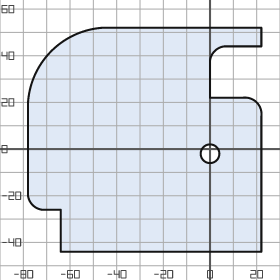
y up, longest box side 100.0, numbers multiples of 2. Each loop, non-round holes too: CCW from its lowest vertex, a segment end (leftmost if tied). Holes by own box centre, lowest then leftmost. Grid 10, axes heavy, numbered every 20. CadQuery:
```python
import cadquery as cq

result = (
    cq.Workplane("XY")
    .moveTo(-64.0, -44.0)
    .lineTo(22.0, -44.0)
    .lineTo(22.0, 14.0)
    .threePointArc((20.0, 20.0), (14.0, 22.0))
    .lineTo(0.0, 22.0)
    .lineTo(0.0, 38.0)
    .threePointArc((2.0, 42.0), (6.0, 44.0))
    .lineTo(22.0, 44.0)
    .lineTo(22.0, 52.0)
    .lineTo(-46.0, 52.0)
    .threePointArc((-68.0, 42.0), (-78.0, 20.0))
    .lineTo(-78.0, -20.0)
    .threePointArc((-76.0, -24.0), (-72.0, -26.0))
    .lineTo(-64.0, -26.0)
    .close()
    .moveTo(0.0, -2.0)
    .circle(4.0)
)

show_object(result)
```